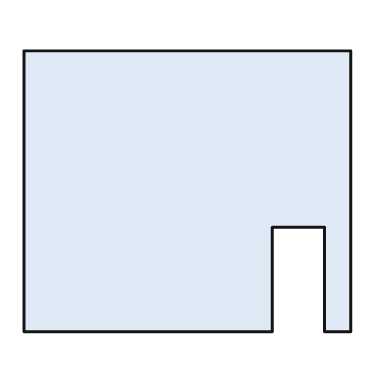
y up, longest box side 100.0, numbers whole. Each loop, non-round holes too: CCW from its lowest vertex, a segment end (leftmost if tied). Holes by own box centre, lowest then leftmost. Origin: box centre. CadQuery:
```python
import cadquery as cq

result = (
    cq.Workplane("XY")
    .moveTo(-50.0, -43.0)
    .lineTo(26.0, -43.0)
    .lineTo(26.0, -11.0)
    .lineTo(42.0, -11.0)
    .lineTo(42.0, -43.0)
    .lineTo(50.0, -43.0)
    .lineTo(50.0, 43.0)
    .lineTo(-50.0, 43.0)
    .close()
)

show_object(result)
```